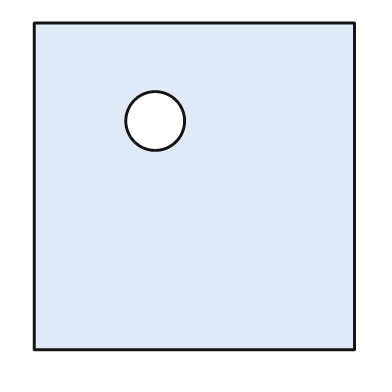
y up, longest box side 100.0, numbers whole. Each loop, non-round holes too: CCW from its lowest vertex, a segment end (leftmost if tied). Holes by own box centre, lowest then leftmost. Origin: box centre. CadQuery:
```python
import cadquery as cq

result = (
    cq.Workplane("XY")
    .moveTo(-49.0, -50.0)
    .lineTo(49.0, -50.0)
    .lineTo(49.0, 50.0)
    .lineTo(-49.0, 50.0)
    .close()
    .moveTo(-12.0, 20.0)
    .circle(9.0)
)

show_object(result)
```